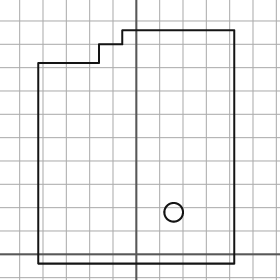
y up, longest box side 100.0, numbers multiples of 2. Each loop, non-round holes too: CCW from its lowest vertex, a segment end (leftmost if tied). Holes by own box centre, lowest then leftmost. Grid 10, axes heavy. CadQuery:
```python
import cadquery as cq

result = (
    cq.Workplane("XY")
    .moveTo(-42.0, -4.0)
    .lineTo(42.0, -4.0)
    .lineTo(42.0, 96.0)
    .lineTo(-6.0, 96.0)
    .lineTo(-6.0, 90.0)
    .lineTo(-16.0, 90.0)
    .lineTo(-16.0, 82.0)
    .lineTo(-42.0, 82.0)
    .close()
    .moveTo(16.0, 18.0)
    .circle(4.0)
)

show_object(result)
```